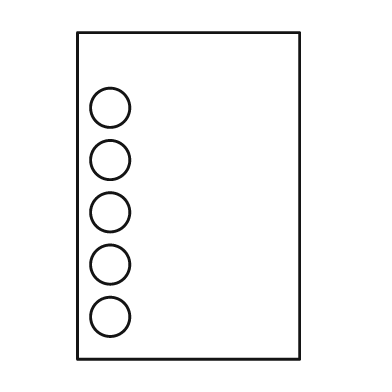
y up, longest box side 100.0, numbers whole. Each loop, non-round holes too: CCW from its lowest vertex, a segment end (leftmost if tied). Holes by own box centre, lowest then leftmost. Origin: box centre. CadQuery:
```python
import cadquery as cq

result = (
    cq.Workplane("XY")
    .moveTo(-34.0, -50.0)
    .lineTo(34.0, -50.0)
    .lineTo(34.0, 50.0)
    .lineTo(-34.0, 50.0)
    .close()
    .moveTo(-24.0, -37.0)
    .circle(6.0)
    .moveTo(-24.0, -21.0)
    .circle(6.0)
    .moveTo(-24.0, -5.0)
    .circle(6.0)
    .moveTo(-24.0, 11.0)
    .circle(6.0)
    .moveTo(-24.0, 27.0)
    .circle(6.0)
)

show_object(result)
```